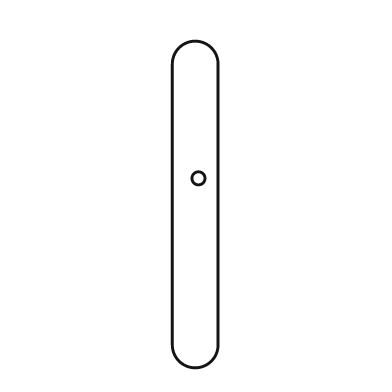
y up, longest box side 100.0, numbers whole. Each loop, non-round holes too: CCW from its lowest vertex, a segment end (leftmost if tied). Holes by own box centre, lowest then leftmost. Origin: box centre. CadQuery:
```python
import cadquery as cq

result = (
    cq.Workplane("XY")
    .moveTo(-7.0, -43.0)
    .threePointArc((0.0, -50.0), (7.0, -43.0))
    .lineTo(7.0, 43.0)
    .threePointArc((0.0, 50.0), (-7.0, 43.0))
    .close()
    .moveTo(1.0, 8.0)
    .circle(2.0)
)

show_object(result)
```